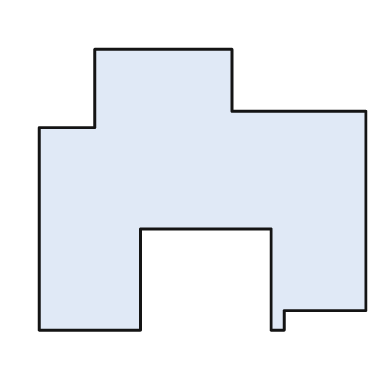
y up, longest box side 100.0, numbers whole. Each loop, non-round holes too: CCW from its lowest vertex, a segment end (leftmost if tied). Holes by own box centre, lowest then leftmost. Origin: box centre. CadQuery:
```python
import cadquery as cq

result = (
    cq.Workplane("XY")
    .moveTo(-50.0, -43.0)
    .lineTo(-19.0, -43.0)
    .lineTo(-19.0, -12.0)
    .lineTo(21.0, -12.0)
    .lineTo(21.0, -43.0)
    .lineTo(25.0, -43.0)
    .lineTo(25.0, -37.0)
    .lineTo(50.0, -37.0)
    .lineTo(50.0, 24.0)
    .lineTo(9.0, 24.0)
    .lineTo(9.0, 43.0)
    .lineTo(-33.0, 43.0)
    .lineTo(-33.0, 19.0)
    .lineTo(-50.0, 19.0)
    .close()
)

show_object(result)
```